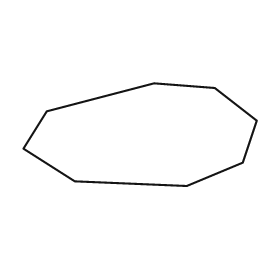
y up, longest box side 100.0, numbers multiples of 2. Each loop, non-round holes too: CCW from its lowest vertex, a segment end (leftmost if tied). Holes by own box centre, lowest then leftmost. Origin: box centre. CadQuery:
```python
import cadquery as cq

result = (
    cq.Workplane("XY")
    .moveTo(20.0, -22.0)
    .lineTo(44.0, -12.0)
    .lineTo(50.0, 6.0)
    .lineTo(32.0, 20.0)
    .lineTo(6.0, 22.0)
    .lineTo(-40.0, 10.0)
    .lineTo(-50.0, -6.0)
    .lineTo(-28.0, -20.0)
    .close()
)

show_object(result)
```